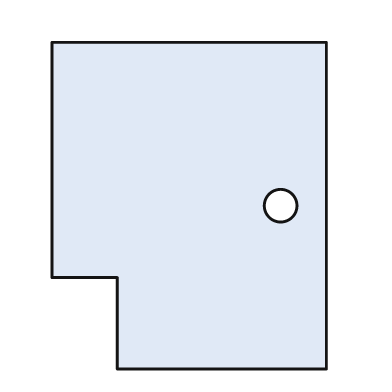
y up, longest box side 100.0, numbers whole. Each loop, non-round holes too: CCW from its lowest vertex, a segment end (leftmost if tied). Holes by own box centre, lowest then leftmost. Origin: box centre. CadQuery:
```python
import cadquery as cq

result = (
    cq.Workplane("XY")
    .moveTo(-22.0, -50.0)
    .lineTo(42.0, -50.0)
    .lineTo(42.0, 50.0)
    .lineTo(-42.0, 50.0)
    .lineTo(-42.0, -22.0)
    .lineTo(-22.0, -22.0)
    .close()
    .moveTo(28.0, 0.0)
    .circle(5.0)
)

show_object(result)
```